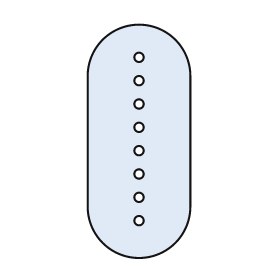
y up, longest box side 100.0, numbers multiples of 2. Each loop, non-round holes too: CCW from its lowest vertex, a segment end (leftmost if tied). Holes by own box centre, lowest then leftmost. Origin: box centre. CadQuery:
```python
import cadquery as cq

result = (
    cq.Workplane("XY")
    .moveTo(-22.0, -28.0)
    .threePointArc((0.0, -50.0), (22.0, -28.0))
    .lineTo(22.0, 28.0)
    .threePointArc((0.0, 50.0), (-22.0, 28.0))
    .close()
    .moveTo(0.0, -34.0)
    .circle(2.0)
    .moveTo(0.0, -24.0)
    .circle(2.0)
    .moveTo(0.0, -14.0)
    .circle(2.0)
    .moveTo(0.0, -4.0)
    .circle(2.0)
    .moveTo(0.0, 6.0)
    .circle(2.0)
    .moveTo(0.0, 16.0)
    .circle(2.0)
    .moveTo(0.0, 26.0)
    .circle(2.0)
    .moveTo(0.0, 36.0)
    .circle(2.0)
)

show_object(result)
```